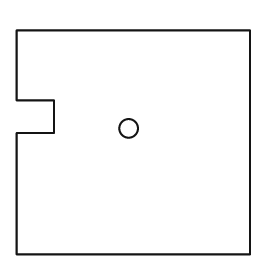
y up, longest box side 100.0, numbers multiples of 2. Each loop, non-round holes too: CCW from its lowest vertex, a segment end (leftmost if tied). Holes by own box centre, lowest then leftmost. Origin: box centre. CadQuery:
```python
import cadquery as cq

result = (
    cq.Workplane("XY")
    .moveTo(-50.0, -48.0)
    .lineTo(50.0, -48.0)
    .lineTo(50.0, 48.0)
    .lineTo(-50.0, 48.0)
    .lineTo(-50.0, 18.0)
    .lineTo(-34.0, 18.0)
    .lineTo(-34.0, 4.0)
    .lineTo(-50.0, 4.0)
    .close()
    .moveTo(-2.0, 6.0)
    .circle(4.0)
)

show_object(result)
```